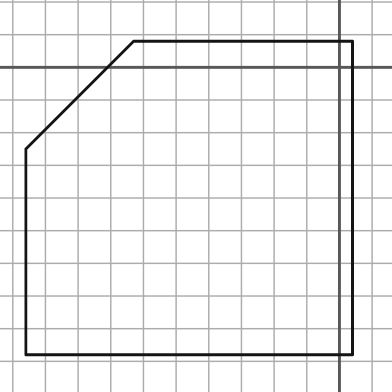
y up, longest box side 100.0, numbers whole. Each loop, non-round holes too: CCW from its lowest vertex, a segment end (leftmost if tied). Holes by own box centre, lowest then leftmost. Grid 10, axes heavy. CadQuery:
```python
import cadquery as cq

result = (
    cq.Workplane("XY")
    .moveTo(-96.0, -88.0)
    .lineTo(4.0, -88.0)
    .lineTo(4.0, 8.0)
    .lineTo(-63.0, 8.0)
    .lineTo(-96.0, -25.0)
    .close()
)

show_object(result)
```